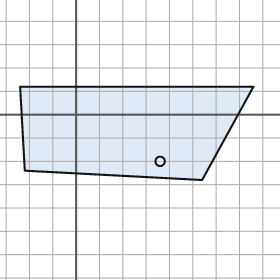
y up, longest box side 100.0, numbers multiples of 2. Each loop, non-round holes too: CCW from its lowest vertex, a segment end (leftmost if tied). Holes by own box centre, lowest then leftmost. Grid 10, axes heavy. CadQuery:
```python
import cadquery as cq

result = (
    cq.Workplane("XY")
    .moveTo(54.0, -28.0)
    .lineTo(76.0, 12.0)
    .lineTo(-24.0, 12.0)
    .lineTo(-22.0, -24.0)
    .close()
    .moveTo(36.0, -20.0)
    .circle(2.0)
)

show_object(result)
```